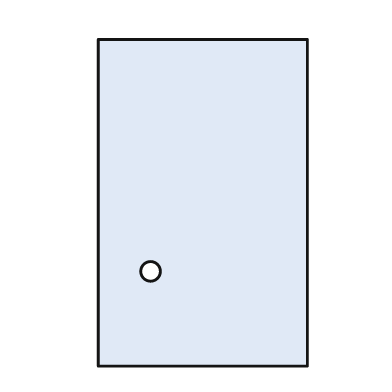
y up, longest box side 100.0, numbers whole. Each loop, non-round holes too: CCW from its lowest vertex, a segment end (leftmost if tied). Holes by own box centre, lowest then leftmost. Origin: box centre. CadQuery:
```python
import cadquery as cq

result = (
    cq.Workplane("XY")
    .moveTo(-32.0, -50.0)
    .lineTo(32.0, -50.0)
    .lineTo(32.0, 50.0)
    .lineTo(-32.0, 50.0)
    .close()
    .moveTo(-16.0, -21.0)
    .circle(3.0)
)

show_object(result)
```